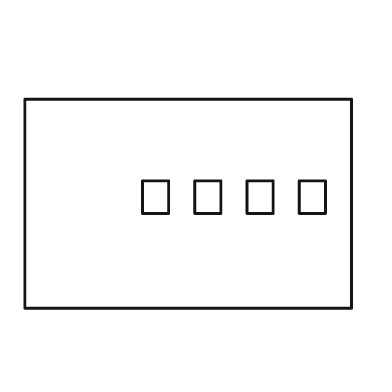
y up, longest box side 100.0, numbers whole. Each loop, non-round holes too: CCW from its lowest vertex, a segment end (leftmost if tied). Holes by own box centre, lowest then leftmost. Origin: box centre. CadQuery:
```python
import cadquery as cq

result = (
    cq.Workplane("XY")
    .moveTo(-50.0, -32.0)
    .lineTo(50.0, -32.0)
    .lineTo(50.0, 32.0)
    .lineTo(-50.0, 32.0)
    .close()
    .moveTo(-14.0, -3.0)
    .lineTo(-6.0, -3.0)
    .lineTo(-6.0, 7.0)
    .lineTo(-14.0, 7.0)
    .close()
    .moveTo(2.0, -3.0)
    .lineTo(10.0, -3.0)
    .lineTo(10.0, 7.0)
    .lineTo(2.0, 7.0)
    .close()
    .moveTo(18.0, -3.0)
    .lineTo(26.0, -3.0)
    .lineTo(26.0, 7.0)
    .lineTo(18.0, 7.0)
    .close()
    .moveTo(34.0, -3.0)
    .lineTo(42.0, -3.0)
    .lineTo(42.0, 7.0)
    .lineTo(34.0, 7.0)
    .close()
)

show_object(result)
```